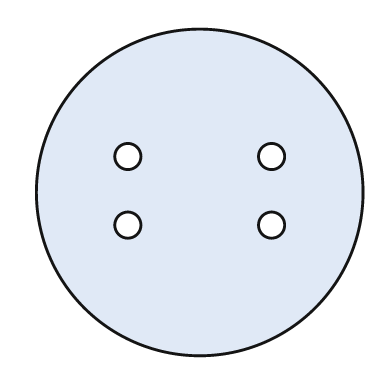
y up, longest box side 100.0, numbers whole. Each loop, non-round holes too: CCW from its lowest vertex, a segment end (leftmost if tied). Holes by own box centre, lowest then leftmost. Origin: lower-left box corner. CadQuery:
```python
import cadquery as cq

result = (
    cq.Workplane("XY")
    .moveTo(50.0, 50.0)
    .circle(50.0)
    .moveTo(28.0, 40.0)
    .circle(4.0)
    .moveTo(72.0, 40.0)
    .circle(4.0)
    .moveTo(28.0, 61.0)
    .circle(4.0)
    .moveTo(72.0, 61.0)
    .circle(4.0)
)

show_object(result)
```